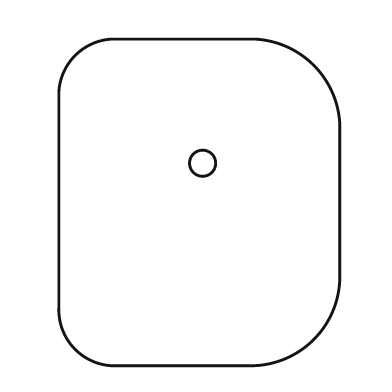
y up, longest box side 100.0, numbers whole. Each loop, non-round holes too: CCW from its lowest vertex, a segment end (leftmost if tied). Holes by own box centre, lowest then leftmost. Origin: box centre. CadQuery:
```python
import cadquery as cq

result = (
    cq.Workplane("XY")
    .moveTo(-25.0, -50.0)
    .lineTo(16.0, -50.0)
    .threePointArc((35.0, -42.0), (43.0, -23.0))
    .lineTo(43.0, 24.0)
    .threePointArc((35.0, 42.0), (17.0, 50.0))
    .lineTo(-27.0, 50.0)
    .threePointArc((-38.0, 45.0), (-43.0, 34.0))
    .lineTo(-43.0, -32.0)
    .threePointArc((-38.0, -45.0), (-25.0, -50.0))
    .close()
    .moveTo(1.0, 12.0)
    .circle(4.0)
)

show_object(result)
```